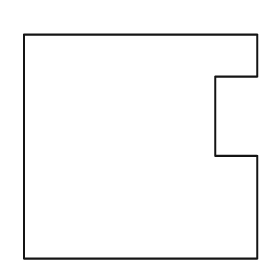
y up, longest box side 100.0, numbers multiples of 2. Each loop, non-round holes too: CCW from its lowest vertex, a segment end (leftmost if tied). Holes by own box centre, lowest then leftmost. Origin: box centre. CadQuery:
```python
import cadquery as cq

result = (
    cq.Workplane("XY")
    .moveTo(-50.0, -48.0)
    .lineTo(50.0, -48.0)
    .lineTo(50.0, -4.0)
    .lineTo(32.0, -4.0)
    .lineTo(32.0, 30.0)
    .lineTo(50.0, 30.0)
    .lineTo(50.0, 48.0)
    .lineTo(-50.0, 48.0)
    .close()
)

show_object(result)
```